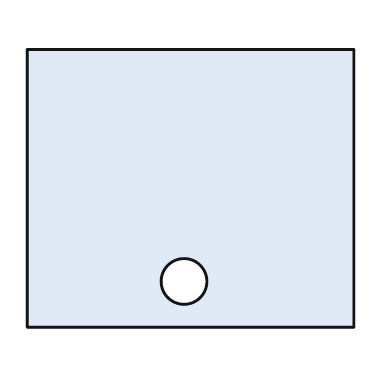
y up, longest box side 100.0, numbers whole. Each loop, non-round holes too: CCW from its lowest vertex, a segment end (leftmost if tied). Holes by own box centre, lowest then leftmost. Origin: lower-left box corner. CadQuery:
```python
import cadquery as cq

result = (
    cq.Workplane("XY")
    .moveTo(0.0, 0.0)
    .lineTo(100.0, 0.0)
    .lineTo(100.0, 85.0)
    .lineTo(0.0, 85.0)
    .close()
    .moveTo(48.0, 14.0)
    .circle(7.0)
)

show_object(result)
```